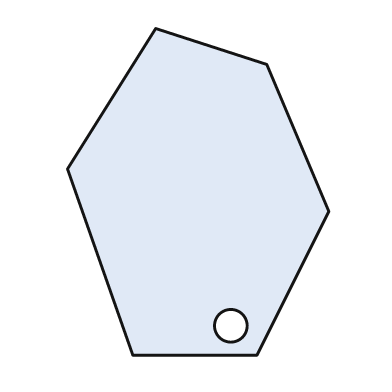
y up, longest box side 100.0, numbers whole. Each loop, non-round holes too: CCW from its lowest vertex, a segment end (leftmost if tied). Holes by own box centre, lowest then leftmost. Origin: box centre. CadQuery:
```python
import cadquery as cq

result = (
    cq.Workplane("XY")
    .moveTo(-20.0, -50.0)
    .lineTo(18.0, -50.0)
    .lineTo(40.0, -6.0)
    .lineTo(21.0, 39.0)
    .lineTo(-13.0, 50.0)
    .lineTo(-40.0, 7.0)
    .close()
    .moveTo(10.0, -41.0)
    .circle(5.0)
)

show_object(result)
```